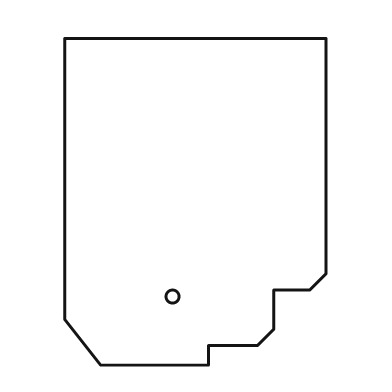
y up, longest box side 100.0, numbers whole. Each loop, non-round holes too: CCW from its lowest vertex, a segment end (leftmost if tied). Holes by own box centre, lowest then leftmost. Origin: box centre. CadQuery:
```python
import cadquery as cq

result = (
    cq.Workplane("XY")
    .moveTo(-29.0, -50.0)
    .lineTo(4.0, -50.0)
    .lineTo(4.0, -44.0)
    .lineTo(19.0, -44.0)
    .lineTo(24.0, -39.0)
    .lineTo(24.0, -27.0)
    .lineTo(35.0, -27.0)
    .lineTo(40.0, -22.0)
    .lineTo(40.0, 50.0)
    .lineTo(-40.0, 50.0)
    .lineTo(-40.0, -36.0)
    .close()
    .moveTo(-7.0, -29.0)
    .circle(2.0)
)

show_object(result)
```